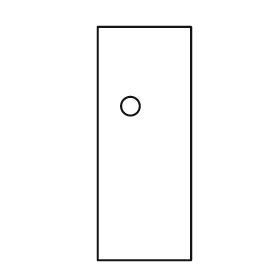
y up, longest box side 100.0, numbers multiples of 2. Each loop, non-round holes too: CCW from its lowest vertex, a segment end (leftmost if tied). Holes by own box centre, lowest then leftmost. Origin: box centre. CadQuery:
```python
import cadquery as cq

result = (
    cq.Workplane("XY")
    .moveTo(-20.0, -50.0)
    .lineTo(20.0, -50.0)
    .lineTo(20.0, 50.0)
    .lineTo(-20.0, 50.0)
    .close()
    .moveTo(-6.0, 16.0)
    .circle(4.0)
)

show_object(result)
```